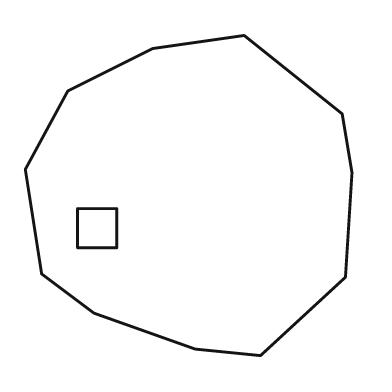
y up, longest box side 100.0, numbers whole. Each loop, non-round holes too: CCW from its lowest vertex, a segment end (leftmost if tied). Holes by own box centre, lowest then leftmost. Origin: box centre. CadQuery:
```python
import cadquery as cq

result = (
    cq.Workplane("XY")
    .moveTo(22.0, -49.0)
    .lineTo(48.0, -25.0)
    .lineTo(50.0, 7.0)
    .lineTo(47.0, 25.0)
    .lineTo(17.0, 49.0)
    .lineTo(-11.0, 45.0)
    .lineTo(-37.0, 32.0)
    .lineTo(-50.0, 8.0)
    .lineTo(-45.0, -24.0)
    .lineTo(-29.0, -36.0)
    .lineTo(2.0, -47.0)
    .close()
    .moveTo(-34.0, -16.0)
    .lineTo(-22.0, -16.0)
    .lineTo(-22.0, -4.0)
    .lineTo(-34.0, -4.0)
    .close()
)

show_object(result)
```